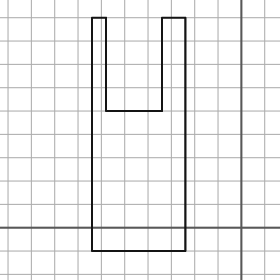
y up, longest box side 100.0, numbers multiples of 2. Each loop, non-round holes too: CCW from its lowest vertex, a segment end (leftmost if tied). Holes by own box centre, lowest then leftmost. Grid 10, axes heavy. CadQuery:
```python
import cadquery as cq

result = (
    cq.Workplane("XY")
    .moveTo(-64.0, -10.0)
    .lineTo(-24.0, -10.0)
    .lineTo(-24.0, 90.0)
    .lineTo(-34.0, 90.0)
    .lineTo(-34.0, 50.0)
    .lineTo(-58.0, 50.0)
    .lineTo(-58.0, 90.0)
    .lineTo(-64.0, 90.0)
    .close()
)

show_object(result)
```